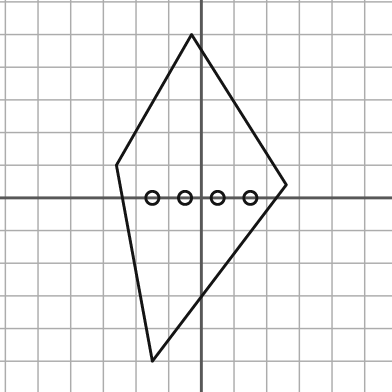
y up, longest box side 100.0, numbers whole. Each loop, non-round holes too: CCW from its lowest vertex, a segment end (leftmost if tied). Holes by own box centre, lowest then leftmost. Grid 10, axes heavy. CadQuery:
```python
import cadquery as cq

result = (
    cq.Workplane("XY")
    .moveTo(-15.0, -50.0)
    .lineTo(26.0, 4.0)
    .lineTo(-3.0, 50.0)
    .lineTo(-26.0, 10.0)
    .close()
    .moveTo(-15.0, 0.0)
    .circle(2.0)
    .moveTo(-5.0, 0.0)
    .circle(2.0)
    .moveTo(5.0, 0.0)
    .circle(2.0)
    .moveTo(15.0, 0.0)
    .circle(2.0)
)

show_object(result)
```